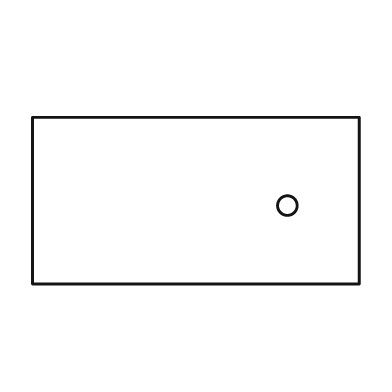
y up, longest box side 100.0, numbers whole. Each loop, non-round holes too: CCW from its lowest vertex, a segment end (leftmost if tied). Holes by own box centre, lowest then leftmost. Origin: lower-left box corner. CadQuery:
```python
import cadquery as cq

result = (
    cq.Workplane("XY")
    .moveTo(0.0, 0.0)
    .lineTo(100.0, 0.0)
    .lineTo(100.0, 51.0)
    .lineTo(0.0, 51.0)
    .close()
    .moveTo(78.0, 24.0)
    .circle(3.0)
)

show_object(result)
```